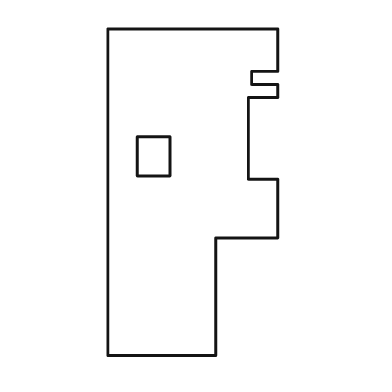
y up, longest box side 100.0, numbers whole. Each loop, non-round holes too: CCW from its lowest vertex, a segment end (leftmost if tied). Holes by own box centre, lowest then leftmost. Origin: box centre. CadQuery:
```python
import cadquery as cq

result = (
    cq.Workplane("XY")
    .moveTo(-26.0, -50.0)
    .lineTo(7.0, -50.0)
    .lineTo(7.0, -14.0)
    .lineTo(26.0, -14.0)
    .lineTo(26.0, 4.0)
    .lineTo(17.0, 4.0)
    .lineTo(17.0, 29.0)
    .lineTo(26.0, 29.0)
    .lineTo(26.0, 33.0)
    .lineTo(18.0, 33.0)
    .lineTo(18.0, 37.0)
    .lineTo(26.0, 37.0)
    .lineTo(26.0, 50.0)
    .lineTo(-26.0, 50.0)
    .close()
    .moveTo(-17.0, 5.0)
    .lineTo(-7.0, 5.0)
    .lineTo(-7.0, 17.0)
    .lineTo(-17.0, 17.0)
    .close()
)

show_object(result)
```